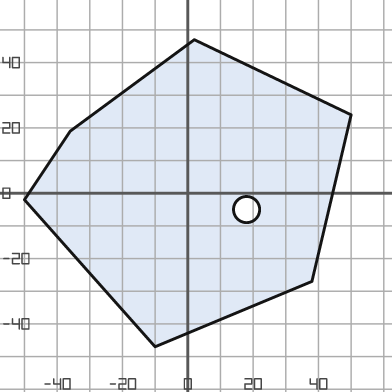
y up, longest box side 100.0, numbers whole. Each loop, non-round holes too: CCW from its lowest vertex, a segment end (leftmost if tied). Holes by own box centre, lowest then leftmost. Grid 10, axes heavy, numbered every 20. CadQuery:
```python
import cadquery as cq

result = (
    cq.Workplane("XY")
    .moveTo(-10.0, -47.0)
    .lineTo(38.0, -27.0)
    .lineTo(50.0, 24.0)
    .lineTo(2.0, 47.0)
    .lineTo(-36.0, 19.0)
    .lineTo(-50.0, -2.0)
    .close()
    .moveTo(18.0, -5.0)
    .circle(4.0)
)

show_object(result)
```